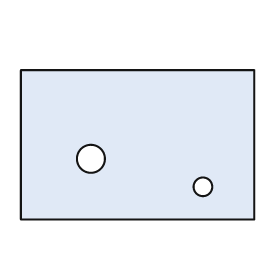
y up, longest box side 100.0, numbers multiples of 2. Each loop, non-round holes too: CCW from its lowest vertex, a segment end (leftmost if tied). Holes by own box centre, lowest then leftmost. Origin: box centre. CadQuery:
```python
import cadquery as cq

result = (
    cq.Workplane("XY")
    .moveTo(-50.0, -32.0)
    .lineTo(50.0, -32.0)
    .lineTo(50.0, 32.0)
    .lineTo(-50.0, 32.0)
    .close()
    .moveTo(28.0, -18.0)
    .circle(4.0)
    .moveTo(-20.0, -6.0)
    .circle(6.0)
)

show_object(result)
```